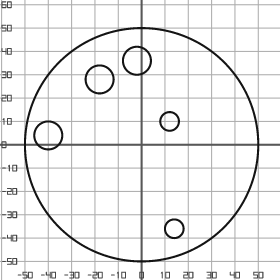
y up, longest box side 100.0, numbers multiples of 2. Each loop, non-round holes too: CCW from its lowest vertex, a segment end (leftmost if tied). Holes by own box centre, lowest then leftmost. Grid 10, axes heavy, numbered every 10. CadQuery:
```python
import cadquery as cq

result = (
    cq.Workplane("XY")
    .moveTo(0.0, 0.0)
    .circle(50.0)
    .moveTo(14.0, -36.0)
    .circle(4.0)
    .moveTo(-40.0, 4.0)
    .circle(6.0)
    .moveTo(12.0, 10.0)
    .circle(4.0)
    .moveTo(-18.0, 28.0)
    .circle(6.0)
    .moveTo(-2.0, 36.0)
    .circle(6.0)
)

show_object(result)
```